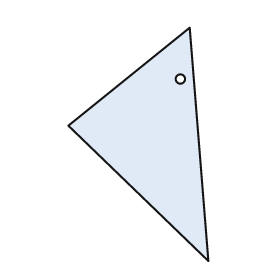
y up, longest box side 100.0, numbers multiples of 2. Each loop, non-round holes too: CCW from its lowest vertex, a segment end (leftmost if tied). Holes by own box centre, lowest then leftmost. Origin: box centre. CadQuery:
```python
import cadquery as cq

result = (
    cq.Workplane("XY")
    .moveTo(30.0, -50.0)
    .lineTo(22.0, 50.0)
    .lineTo(-30.0, 8.0)
    .close()
    .moveTo(18.0, 28.0)
    .circle(2.0)
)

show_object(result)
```